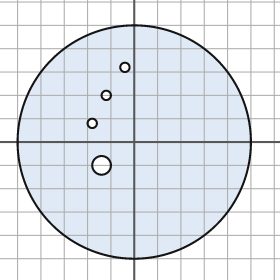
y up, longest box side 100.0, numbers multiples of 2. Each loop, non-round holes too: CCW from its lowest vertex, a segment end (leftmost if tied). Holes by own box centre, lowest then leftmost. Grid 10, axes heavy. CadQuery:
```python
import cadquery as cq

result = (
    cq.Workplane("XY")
    .moveTo(0.0, 0.0)
    .circle(50.0)
    .moveTo(-14.0, -10.0)
    .circle(4.0)
    .moveTo(-18.0, 8.0)
    .circle(2.0)
    .moveTo(-12.0, 20.0)
    .circle(2.0)
    .moveTo(-4.0, 32.0)
    .circle(2.0)
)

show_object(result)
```